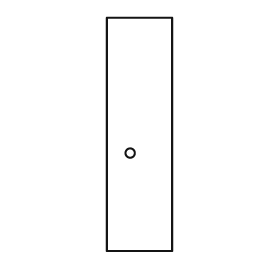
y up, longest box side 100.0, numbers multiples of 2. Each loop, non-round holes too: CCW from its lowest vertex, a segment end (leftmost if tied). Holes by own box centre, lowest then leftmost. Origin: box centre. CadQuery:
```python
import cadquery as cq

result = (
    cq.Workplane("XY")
    .moveTo(-14.0, -50.0)
    .lineTo(14.0, -50.0)
    .lineTo(14.0, 50.0)
    .lineTo(-14.0, 50.0)
    .close()
    .moveTo(-4.0, -8.0)
    .circle(2.0)
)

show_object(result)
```